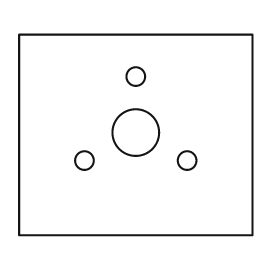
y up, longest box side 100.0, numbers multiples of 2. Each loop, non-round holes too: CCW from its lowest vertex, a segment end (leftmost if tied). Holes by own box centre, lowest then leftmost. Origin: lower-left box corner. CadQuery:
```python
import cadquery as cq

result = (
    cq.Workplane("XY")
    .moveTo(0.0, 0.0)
    .lineTo(100.0, 0.0)
    .lineTo(100.0, 86.0)
    .lineTo(0.0, 86.0)
    .close()
    .moveTo(28.0, 32.0)
    .circle(4.0)
    .moveTo(72.0, 32.0)
    .circle(4.0)
    .moveTo(50.0, 44.0)
    .circle(10.0)
    .moveTo(50.0, 68.0)
    .circle(4.0)
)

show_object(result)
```